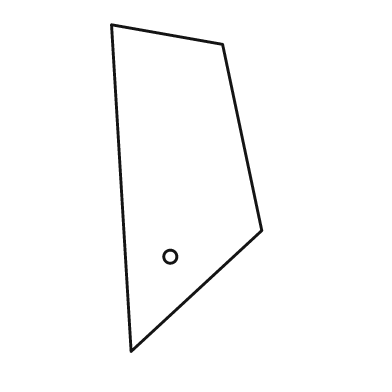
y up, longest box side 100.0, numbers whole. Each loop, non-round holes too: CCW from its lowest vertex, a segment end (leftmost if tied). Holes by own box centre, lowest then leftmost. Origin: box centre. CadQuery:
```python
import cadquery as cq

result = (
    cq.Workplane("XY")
    .moveTo(-17.0, -50.0)
    .lineTo(23.0, -13.0)
    .lineTo(11.0, 44.0)
    .lineTo(-23.0, 50.0)
    .close()
    .moveTo(-5.0, -21.0)
    .circle(2.0)
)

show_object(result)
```